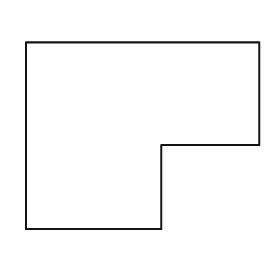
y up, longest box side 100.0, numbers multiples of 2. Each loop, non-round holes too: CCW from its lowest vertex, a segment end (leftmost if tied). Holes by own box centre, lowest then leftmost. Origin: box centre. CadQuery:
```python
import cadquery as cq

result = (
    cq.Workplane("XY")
    .moveTo(-50.0, -40.0)
    .lineTo(8.0, -40.0)
    .lineTo(8.0, -4.0)
    .lineTo(50.0, -4.0)
    .lineTo(50.0, 40.0)
    .lineTo(-50.0, 40.0)
    .close()
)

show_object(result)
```